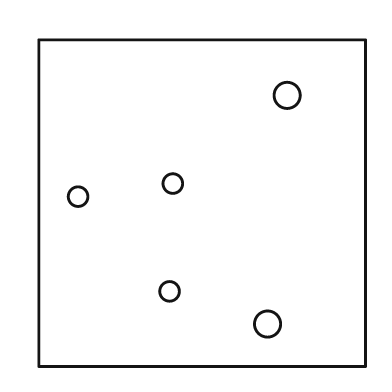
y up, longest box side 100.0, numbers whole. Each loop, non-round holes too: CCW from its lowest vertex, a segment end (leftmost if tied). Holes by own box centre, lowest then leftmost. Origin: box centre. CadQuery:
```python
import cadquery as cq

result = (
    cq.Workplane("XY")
    .moveTo(-50.0, -50.0)
    .lineTo(50.0, -50.0)
    .lineTo(50.0, 50.0)
    .lineTo(-50.0, 50.0)
    .close()
    .moveTo(20.0, -37.0)
    .circle(4.0)
    .moveTo(-10.0, -27.0)
    .circle(3.0)
    .moveTo(-38.0, 2.0)
    .circle(3.0)
    .moveTo(-9.0, 6.0)
    .circle(3.0)
    .moveTo(26.0, 33.0)
    .circle(4.0)
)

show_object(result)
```